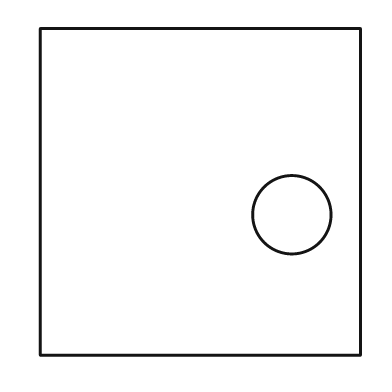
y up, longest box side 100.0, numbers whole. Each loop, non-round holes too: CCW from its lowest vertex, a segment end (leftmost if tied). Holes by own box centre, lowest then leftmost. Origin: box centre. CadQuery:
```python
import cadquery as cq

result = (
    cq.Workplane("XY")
    .moveTo(-49.0, -50.0)
    .lineTo(49.0, -50.0)
    .lineTo(49.0, 50.0)
    .lineTo(-49.0, 50.0)
    .close()
    .moveTo(28.0, -7.0)
    .circle(12.0)
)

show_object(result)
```